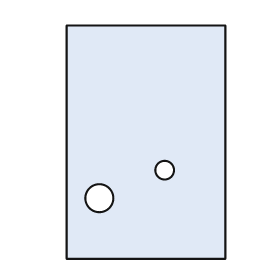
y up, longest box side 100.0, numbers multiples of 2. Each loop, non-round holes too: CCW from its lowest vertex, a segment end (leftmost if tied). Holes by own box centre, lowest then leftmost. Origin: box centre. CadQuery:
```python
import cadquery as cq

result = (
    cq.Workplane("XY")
    .moveTo(-34.0, -50.0)
    .lineTo(34.0, -50.0)
    .lineTo(34.0, 50.0)
    .lineTo(-34.0, 50.0)
    .close()
    .moveTo(-20.0, -24.0)
    .circle(6.0)
    .moveTo(8.0, -12.0)
    .circle(4.0)
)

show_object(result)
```